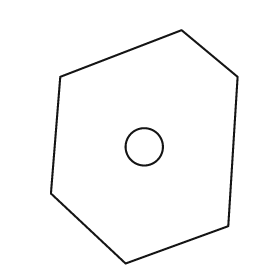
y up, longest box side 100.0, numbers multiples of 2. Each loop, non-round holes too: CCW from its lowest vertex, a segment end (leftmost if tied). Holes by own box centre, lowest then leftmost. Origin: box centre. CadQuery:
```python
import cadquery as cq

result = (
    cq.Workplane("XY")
    .moveTo(-8.0, -50.0)
    .lineTo(36.0, -34.0)
    .lineTo(40.0, 30.0)
    .lineTo(16.0, 50.0)
    .lineTo(-36.0, 30.0)
    .lineTo(-40.0, -20.0)
    .close()
    .moveTo(0.0, 0.0)
    .circle(8.0)
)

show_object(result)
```